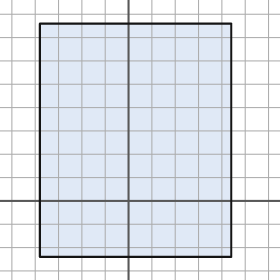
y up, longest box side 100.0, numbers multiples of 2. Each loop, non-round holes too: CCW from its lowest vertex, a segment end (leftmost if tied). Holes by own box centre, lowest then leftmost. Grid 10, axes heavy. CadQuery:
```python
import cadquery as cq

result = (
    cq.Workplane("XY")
    .moveTo(-38.0, -24.0)
    .lineTo(44.0, -24.0)
    .lineTo(44.0, 76.0)
    .lineTo(-38.0, 76.0)
    .close()
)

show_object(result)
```